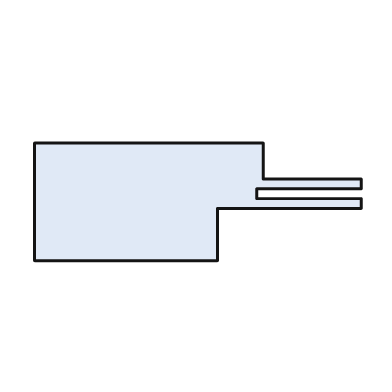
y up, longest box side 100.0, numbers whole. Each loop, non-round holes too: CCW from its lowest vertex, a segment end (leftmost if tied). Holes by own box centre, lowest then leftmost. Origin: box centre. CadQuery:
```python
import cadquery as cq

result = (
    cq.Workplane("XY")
    .moveTo(-50.0, -18.0)
    .lineTo(6.0, -18.0)
    .lineTo(6.0, -2.0)
    .lineTo(50.0, -2.0)
    .lineTo(50.0, 1.0)
    .lineTo(18.0, 1.0)
    .lineTo(18.0, 4.0)
    .lineTo(50.0, 4.0)
    .lineTo(50.0, 7.0)
    .lineTo(20.0, 7.0)
    .lineTo(20.0, 18.0)
    .lineTo(-50.0, 18.0)
    .close()
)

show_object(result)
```